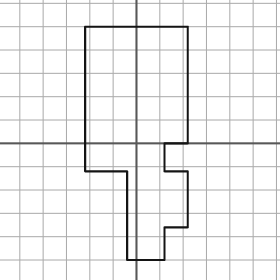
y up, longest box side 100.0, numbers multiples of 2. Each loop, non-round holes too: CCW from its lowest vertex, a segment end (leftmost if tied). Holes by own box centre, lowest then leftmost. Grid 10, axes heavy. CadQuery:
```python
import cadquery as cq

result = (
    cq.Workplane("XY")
    .moveTo(-4.0, -50.0)
    .lineTo(12.0, -50.0)
    .lineTo(12.0, -36.0)
    .lineTo(22.0, -36.0)
    .lineTo(22.0, -12.0)
    .lineTo(12.0, -12.0)
    .lineTo(12.0, 0.0)
    .lineTo(22.0, 0.0)
    .lineTo(22.0, 50.0)
    .lineTo(-22.0, 50.0)
    .lineTo(-22.0, -12.0)
    .lineTo(-4.0, -12.0)
    .close()
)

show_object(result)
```